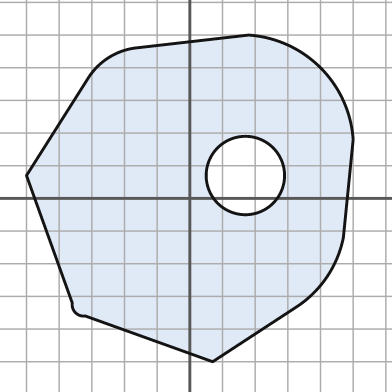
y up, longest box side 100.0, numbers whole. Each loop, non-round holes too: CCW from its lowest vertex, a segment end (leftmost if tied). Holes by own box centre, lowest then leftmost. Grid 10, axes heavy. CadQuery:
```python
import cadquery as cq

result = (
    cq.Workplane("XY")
    .moveTo(7.0, -50.0)
    .lineTo(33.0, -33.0)
    .threePointArc((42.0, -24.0), (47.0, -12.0))
    .lineTo(50.0, 18.0)
    .threePointArc((40.0, 40.0), (18.0, 50.0))
    .lineTo(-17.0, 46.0)
    .threePointArc((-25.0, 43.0), (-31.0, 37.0))
    .lineTo(-50.0, 7.0)
    .lineTo(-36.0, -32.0)
    .threePointArc((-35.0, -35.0), (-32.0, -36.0))
    .close()
    .moveTo(17.0, 7.0)
    .circle(12.0)
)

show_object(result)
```